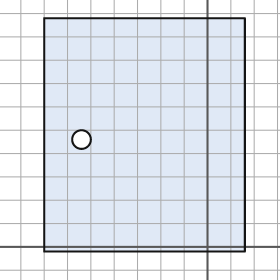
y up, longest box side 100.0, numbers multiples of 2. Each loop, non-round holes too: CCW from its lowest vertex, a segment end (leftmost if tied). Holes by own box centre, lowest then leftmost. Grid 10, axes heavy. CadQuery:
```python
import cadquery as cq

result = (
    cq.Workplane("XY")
    .moveTo(-70.0, -2.0)
    .lineTo(16.0, -2.0)
    .lineTo(16.0, 98.0)
    .lineTo(-70.0, 98.0)
    .close()
    .moveTo(-54.0, 46.0)
    .circle(4.0)
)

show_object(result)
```